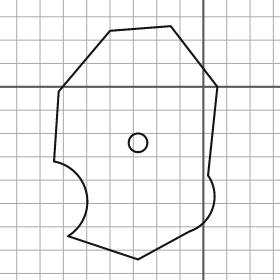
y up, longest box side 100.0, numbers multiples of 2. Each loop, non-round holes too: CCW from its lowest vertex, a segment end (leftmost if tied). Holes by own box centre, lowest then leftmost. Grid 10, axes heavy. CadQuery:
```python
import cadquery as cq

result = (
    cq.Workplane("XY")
    .moveTo(-28.0, -74.0)
    .lineTo(-6.0, -62.0)
    .threePointArc((4.0, -52.0), (2.0, -38.0))
    .lineTo(6.0, 0.0)
    .lineTo(-14.0, 26.0)
    .lineTo(-40.0, 24.0)
    .lineTo(-62.0, -2.0)
    .lineTo(-64.0, -32.0)
    .threePointArc((-50.0, -46.0), (-58.0, -64.0))
    .close()
    .moveTo(-28.0, -24.0)
    .circle(4.0)
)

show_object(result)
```